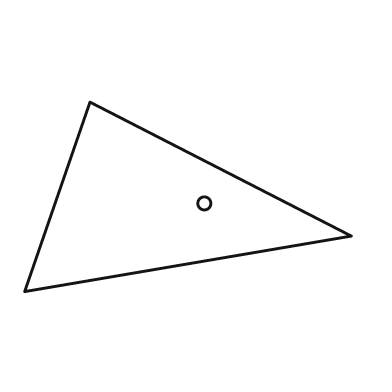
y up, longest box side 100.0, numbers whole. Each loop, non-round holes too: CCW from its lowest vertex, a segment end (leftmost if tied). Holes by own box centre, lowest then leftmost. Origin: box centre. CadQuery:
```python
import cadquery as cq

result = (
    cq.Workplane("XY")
    .moveTo(-50.0, -29.0)
    .lineTo(50.0, -12.0)
    .lineTo(-30.0, 29.0)
    .close()
    .moveTo(5.0, -2.0)
    .circle(2.0)
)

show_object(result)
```